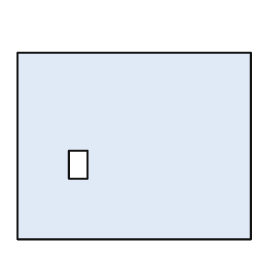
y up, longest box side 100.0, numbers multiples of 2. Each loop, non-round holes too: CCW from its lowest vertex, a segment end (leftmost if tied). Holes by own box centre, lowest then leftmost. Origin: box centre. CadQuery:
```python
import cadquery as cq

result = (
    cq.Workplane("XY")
    .moveTo(-50.0, -40.0)
    .lineTo(50.0, -40.0)
    .lineTo(50.0, 40.0)
    .lineTo(-50.0, 40.0)
    .close()
    .moveTo(-28.0, -14.0)
    .lineTo(-20.0, -14.0)
    .lineTo(-20.0, -2.0)
    .lineTo(-28.0, -2.0)
    .close()
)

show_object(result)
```